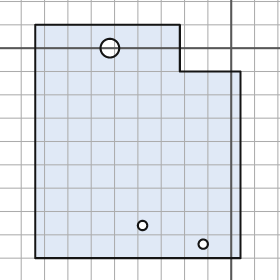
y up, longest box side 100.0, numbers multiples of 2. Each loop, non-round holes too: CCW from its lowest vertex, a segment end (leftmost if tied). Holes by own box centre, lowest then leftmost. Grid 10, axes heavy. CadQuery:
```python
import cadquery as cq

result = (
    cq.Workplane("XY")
    .moveTo(-84.0, -90.0)
    .lineTo(4.0, -90.0)
    .lineTo(4.0, -10.0)
    .lineTo(-22.0, -10.0)
    .lineTo(-22.0, 10.0)
    .lineTo(-84.0, 10.0)
    .close()
    .moveTo(-12.0, -84.0)
    .circle(2.0)
    .moveTo(-38.0, -76.0)
    .circle(2.0)
    .moveTo(-52.0, 0.0)
    .circle(4.0)
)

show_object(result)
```